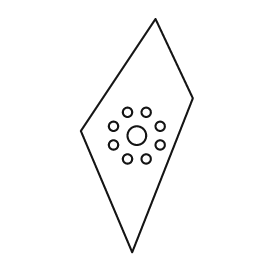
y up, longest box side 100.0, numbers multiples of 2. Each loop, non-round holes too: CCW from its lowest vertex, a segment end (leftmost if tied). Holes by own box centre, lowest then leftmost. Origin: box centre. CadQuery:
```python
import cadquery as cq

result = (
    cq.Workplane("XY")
    .moveTo(-2.0, -50.0)
    .lineTo(24.0, 16.0)
    .lineTo(8.0, 50.0)
    .lineTo(-24.0, 2.0)
    .close()
    .moveTo(-4.0, -10.0)
    .circle(2.0)
    .moveTo(4.0, -10.0)
    .circle(2.0)
    .moveTo(-10.0, -4.0)
    .circle(2.0)
    .moveTo(10.0, -4.0)
    .circle(2.0)
    .moveTo(0.0, 0.0)
    .circle(4.0)
    .moveTo(-10.0, 4.0)
    .circle(2.0)
    .moveTo(10.0, 4.0)
    .circle(2.0)
    .moveTo(-4.0, 10.0)
    .circle(2.0)
    .moveTo(4.0, 10.0)
    .circle(2.0)
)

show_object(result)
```